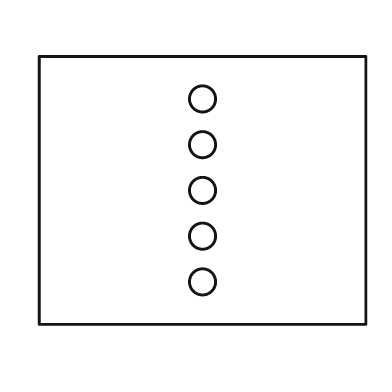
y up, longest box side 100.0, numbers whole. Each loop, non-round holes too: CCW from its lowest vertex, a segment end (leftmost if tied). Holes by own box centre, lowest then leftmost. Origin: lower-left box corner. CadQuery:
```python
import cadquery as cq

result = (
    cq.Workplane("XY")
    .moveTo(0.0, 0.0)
    .lineTo(100.0, 0.0)
    .lineTo(100.0, 82.0)
    .lineTo(0.0, 82.0)
    .close()
    .moveTo(50.0, 13.0)
    .circle(4.0)
    .moveTo(50.0, 27.0)
    .circle(4.0)
    .moveTo(50.0, 41.0)
    .circle(4.0)
    .moveTo(50.0, 55.0)
    .circle(4.0)
    .moveTo(50.0, 69.0)
    .circle(4.0)
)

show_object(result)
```